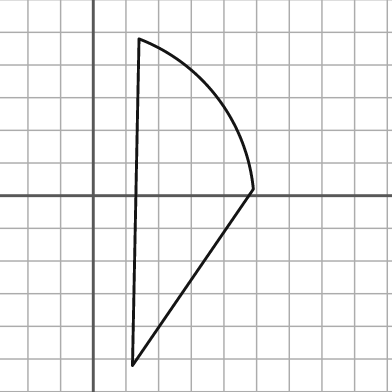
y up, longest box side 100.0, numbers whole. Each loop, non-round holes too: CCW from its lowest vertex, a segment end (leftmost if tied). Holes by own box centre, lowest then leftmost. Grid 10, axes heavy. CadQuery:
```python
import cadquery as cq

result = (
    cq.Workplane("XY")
    .moveTo(12.0, -52.0)
    .lineTo(49.0, 2.0)
    .threePointArc((38.0, 30.0), (14.0, 48.0))
    .close()
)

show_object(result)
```